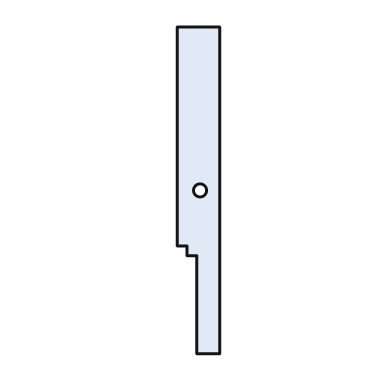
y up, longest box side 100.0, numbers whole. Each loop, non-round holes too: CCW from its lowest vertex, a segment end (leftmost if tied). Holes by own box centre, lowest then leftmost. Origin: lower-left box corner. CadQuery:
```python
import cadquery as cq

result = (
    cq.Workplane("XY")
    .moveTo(6.0, 0.0)
    .lineTo(13.0, 0.0)
    .lineTo(13.0, 100.0)
    .lineTo(0.0, 100.0)
    .lineTo(0.0, 33.0)
    .lineTo(3.0, 33.0)
    .lineTo(3.0, 30.0)
    .lineTo(6.0, 30.0)
    .close()
    .moveTo(7.0, 50.0)
    .circle(2.0)
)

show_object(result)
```